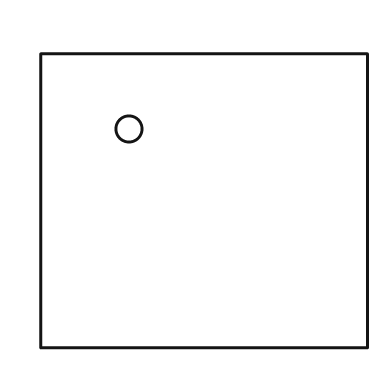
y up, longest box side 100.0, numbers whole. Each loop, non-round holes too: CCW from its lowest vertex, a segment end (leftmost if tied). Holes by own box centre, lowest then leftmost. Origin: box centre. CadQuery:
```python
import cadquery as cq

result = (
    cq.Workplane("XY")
    .moveTo(-50.0, -45.0)
    .lineTo(50.0, -45.0)
    .lineTo(50.0, 45.0)
    .lineTo(-50.0, 45.0)
    .close()
    .moveTo(-23.0, 22.0)
    .circle(4.0)
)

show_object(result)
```